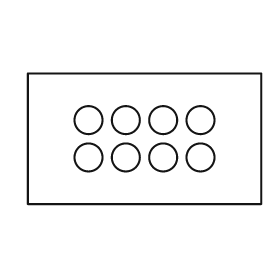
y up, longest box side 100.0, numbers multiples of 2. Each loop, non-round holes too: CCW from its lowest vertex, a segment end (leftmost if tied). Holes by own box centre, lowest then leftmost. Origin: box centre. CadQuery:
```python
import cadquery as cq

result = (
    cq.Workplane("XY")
    .moveTo(-50.0, -28.0)
    .lineTo(50.0, -28.0)
    .lineTo(50.0, 28.0)
    .lineTo(-50.0, 28.0)
    .close()
    .moveTo(-24.0, -8.0)
    .circle(6.0)
    .moveTo(-8.0, -8.0)
    .circle(6.0)
    .moveTo(8.0, -8.0)
    .circle(6.0)
    .moveTo(24.0, -8.0)
    .circle(6.0)
    .moveTo(-24.0, 8.0)
    .circle(6.0)
    .moveTo(-8.0, 8.0)
    .circle(6.0)
    .moveTo(8.0, 8.0)
    .circle(6.0)
    .moveTo(24.0, 8.0)
    .circle(6.0)
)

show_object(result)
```